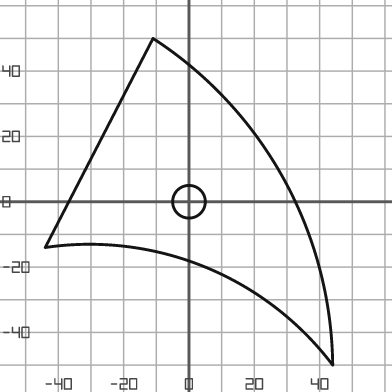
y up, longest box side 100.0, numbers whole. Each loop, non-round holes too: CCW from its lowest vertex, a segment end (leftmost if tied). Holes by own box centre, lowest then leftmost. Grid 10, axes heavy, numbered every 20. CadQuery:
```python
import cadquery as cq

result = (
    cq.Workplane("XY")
    .moveTo(44.0, -50.0)
    .threePointArc((29.0, 7.0), (-11.0, 50.0))
    .lineTo(-44.0, -14.0)
    .threePointArc((5.0, -20.0), (44.0, -50.0))
    .close()
    .moveTo(0.0, 0.0)
    .circle(5.0)
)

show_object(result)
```